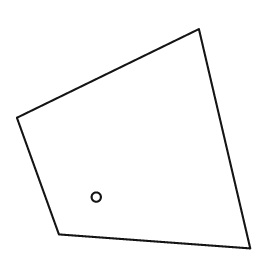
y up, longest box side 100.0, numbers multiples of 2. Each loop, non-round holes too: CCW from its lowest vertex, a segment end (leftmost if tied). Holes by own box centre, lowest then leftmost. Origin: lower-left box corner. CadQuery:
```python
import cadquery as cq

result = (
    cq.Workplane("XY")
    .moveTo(100.0, 0.0)
    .lineTo(78.0, 94.0)
    .lineTo(0.0, 56.0)
    .lineTo(18.0, 6.0)
    .close()
    .moveTo(34.0, 22.0)
    .circle(2.0)
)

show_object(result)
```